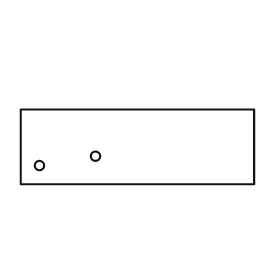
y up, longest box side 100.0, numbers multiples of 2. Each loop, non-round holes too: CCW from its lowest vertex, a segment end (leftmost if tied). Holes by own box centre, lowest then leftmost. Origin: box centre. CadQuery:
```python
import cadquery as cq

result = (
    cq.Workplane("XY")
    .moveTo(-50.0, -16.0)
    .lineTo(50.0, -16.0)
    .lineTo(50.0, 16.0)
    .lineTo(-50.0, 16.0)
    .close()
    .moveTo(-42.0, -8.0)
    .circle(2.0)
    .moveTo(-18.0, -4.0)
    .circle(2.0)
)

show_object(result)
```